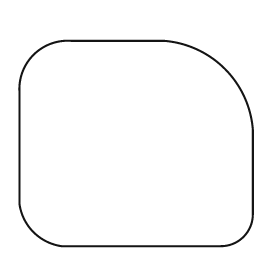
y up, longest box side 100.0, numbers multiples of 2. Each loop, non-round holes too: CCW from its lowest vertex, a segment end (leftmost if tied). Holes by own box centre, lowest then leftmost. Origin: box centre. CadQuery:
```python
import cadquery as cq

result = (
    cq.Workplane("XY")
    .moveTo(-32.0, -44.0)
    .lineTo(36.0, -44.0)
    .threePointArc((46.0, -40.0), (50.0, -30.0))
    .lineTo(50.0, 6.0)
    .threePointArc((38.0, 32.0), (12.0, 44.0))
    .lineTo(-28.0, 44.0)
    .threePointArc((-44.0, 38.0), (-50.0, 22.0))
    .lineTo(-50.0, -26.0)
    .threePointArc((-44.0, -38.0), (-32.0, -44.0))
    .close()
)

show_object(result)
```